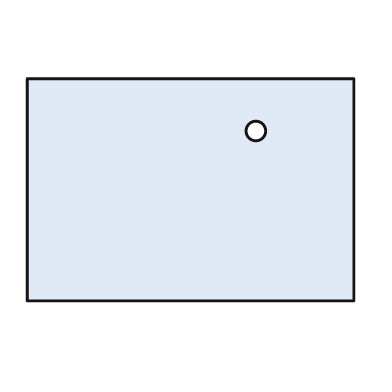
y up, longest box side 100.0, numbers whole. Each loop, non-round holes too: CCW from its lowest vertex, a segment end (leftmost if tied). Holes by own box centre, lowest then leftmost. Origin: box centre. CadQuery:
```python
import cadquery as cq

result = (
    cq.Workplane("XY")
    .moveTo(-50.0, -34.0)
    .lineTo(50.0, -34.0)
    .lineTo(50.0, 34.0)
    .lineTo(-50.0, 34.0)
    .close()
    .moveTo(20.0, 18.0)
    .circle(3.0)
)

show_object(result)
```